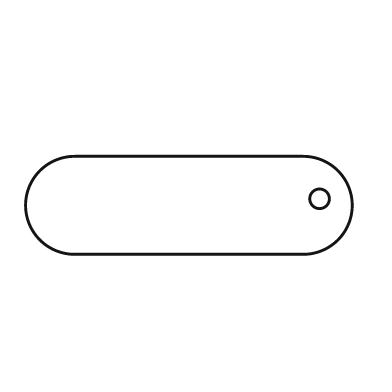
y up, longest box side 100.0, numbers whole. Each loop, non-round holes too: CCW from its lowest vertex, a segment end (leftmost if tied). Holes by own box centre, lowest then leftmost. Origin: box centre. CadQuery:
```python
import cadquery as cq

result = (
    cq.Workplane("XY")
    .moveTo(-35.0, -15.0)
    .lineTo(35.0, -15.0)
    .threePointArc((50.0, 0.0), (35.0, 15.0))
    .lineTo(-35.0, 15.0)
    .threePointArc((-50.0, 0.0), (-35.0, -15.0))
    .close()
    .moveTo(40.0, 2.0)
    .circle(3.0)
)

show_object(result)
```